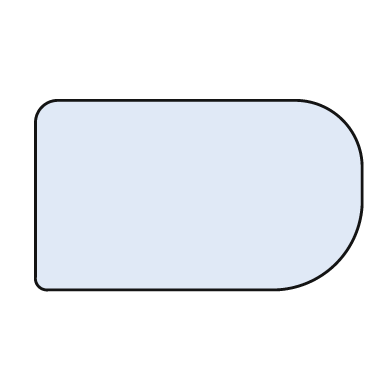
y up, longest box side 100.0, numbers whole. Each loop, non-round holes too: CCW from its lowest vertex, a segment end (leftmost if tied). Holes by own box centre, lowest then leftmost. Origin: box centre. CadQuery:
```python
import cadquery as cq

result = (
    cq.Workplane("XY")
    .moveTo(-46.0, -29.0)
    .lineTo(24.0, -29.0)
    .threePointArc((42.0, -21.0), (50.0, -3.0))
    .lineTo(50.0, 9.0)
    .threePointArc((44.0, 23.0), (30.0, 29.0))
    .lineTo(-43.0, 29.0)
    .threePointArc((-48.0, 27.0), (-50.0, 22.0))
    .lineTo(-50.0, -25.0)
    .threePointArc((-49.0, -28.0), (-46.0, -29.0))
    .close()
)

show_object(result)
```